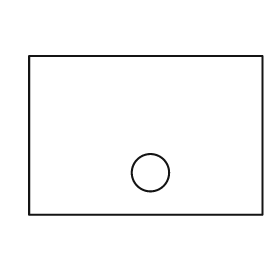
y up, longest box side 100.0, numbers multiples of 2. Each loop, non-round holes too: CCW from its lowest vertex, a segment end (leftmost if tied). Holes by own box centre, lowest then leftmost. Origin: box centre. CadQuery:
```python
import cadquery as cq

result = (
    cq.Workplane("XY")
    .moveTo(-50.0, -34.0)
    .lineTo(50.0, -34.0)
    .lineTo(50.0, 34.0)
    .lineTo(-50.0, 34.0)
    .close()
    .moveTo(2.0, -16.0)
    .circle(8.0)
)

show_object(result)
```